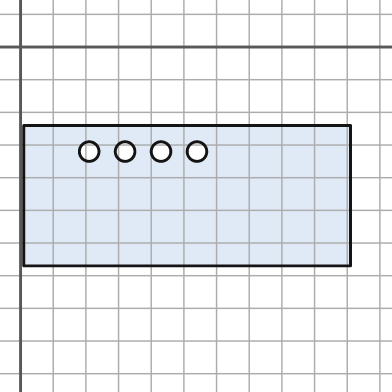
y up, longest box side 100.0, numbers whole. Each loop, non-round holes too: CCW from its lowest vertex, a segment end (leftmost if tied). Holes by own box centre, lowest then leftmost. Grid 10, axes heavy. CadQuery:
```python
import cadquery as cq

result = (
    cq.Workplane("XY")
    .moveTo(1.0, -67.0)
    .lineTo(101.0, -67.0)
    .lineTo(101.0, -24.0)
    .lineTo(1.0, -24.0)
    .close()
    .moveTo(21.0, -32.0)
    .circle(3.0)
    .moveTo(32.0, -32.0)
    .circle(3.0)
    .moveTo(43.0, -32.0)
    .circle(3.0)
    .moveTo(54.0, -32.0)
    .circle(3.0)
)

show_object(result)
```